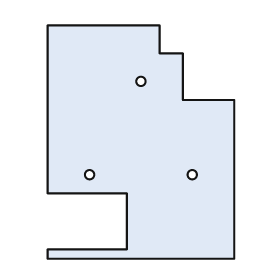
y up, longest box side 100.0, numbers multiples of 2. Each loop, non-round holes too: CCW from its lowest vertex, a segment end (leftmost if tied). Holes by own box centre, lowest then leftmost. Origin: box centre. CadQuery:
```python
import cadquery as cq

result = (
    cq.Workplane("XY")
    .moveTo(-40.0, -50.0)
    .lineTo(40.0, -50.0)
    .lineTo(40.0, 18.0)
    .lineTo(18.0, 18.0)
    .lineTo(18.0, 38.0)
    .lineTo(8.0, 38.0)
    .lineTo(8.0, 50.0)
    .lineTo(-40.0, 50.0)
    .lineTo(-40.0, -22.0)
    .lineTo(-6.0, -22.0)
    .lineTo(-6.0, -46.0)
    .lineTo(-40.0, -46.0)
    .close()
    .moveTo(-22.0, -14.0)
    .circle(2.0)
    .moveTo(22.0, -14.0)
    .circle(2.0)
    .moveTo(0.0, 26.0)
    .circle(2.0)
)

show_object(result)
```